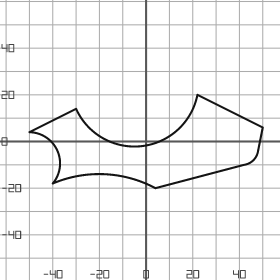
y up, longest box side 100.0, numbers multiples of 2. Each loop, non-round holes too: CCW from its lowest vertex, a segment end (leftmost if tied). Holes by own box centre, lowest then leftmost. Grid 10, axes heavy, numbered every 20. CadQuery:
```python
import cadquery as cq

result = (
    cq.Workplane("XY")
    .moveTo(4.0, -20.0)
    .lineTo(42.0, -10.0)
    .threePointArc((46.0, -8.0), (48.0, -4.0))
    .lineTo(50.0, 6.0)
    .lineTo(22.0, 20.0)
    .threePointArc((-2.0, -2.0), (-30.0, 14.0))
    .lineTo(-50.0, 4.0)
    .threePointArc((-38.0, -4.0), (-40.0, -18.0))
    .threePointArc((-18.0, -14.0), (4.0, -20.0))
    .close()
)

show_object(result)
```